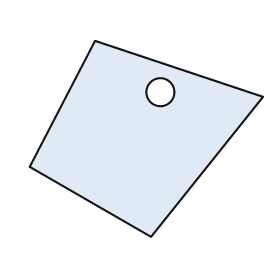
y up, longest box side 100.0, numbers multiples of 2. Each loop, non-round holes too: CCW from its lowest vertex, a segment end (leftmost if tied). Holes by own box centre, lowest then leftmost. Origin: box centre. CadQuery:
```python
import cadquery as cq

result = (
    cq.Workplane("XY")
    .moveTo(2.0, -42.0)
    .lineTo(50.0, 18.0)
    .lineTo(-22.0, 42.0)
    .lineTo(-50.0, -12.0)
    .close()
    .moveTo(6.0, 20.0)
    .circle(6.0)
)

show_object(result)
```